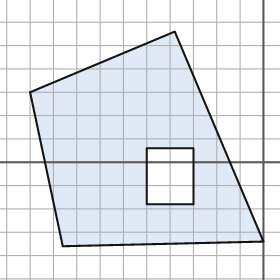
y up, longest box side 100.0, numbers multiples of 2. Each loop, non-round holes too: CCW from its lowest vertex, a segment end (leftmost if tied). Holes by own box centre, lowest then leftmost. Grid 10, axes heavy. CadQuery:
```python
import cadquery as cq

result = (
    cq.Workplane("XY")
    .moveTo(-86.0, -36.0)
    .lineTo(0.0, -34.0)
    .lineTo(-38.0, 56.0)
    .lineTo(-100.0, 30.0)
    .close()
    .moveTo(-50.0, -18.0)
    .lineTo(-30.0, -18.0)
    .lineTo(-30.0, 6.0)
    .lineTo(-50.0, 6.0)
    .close()
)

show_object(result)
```